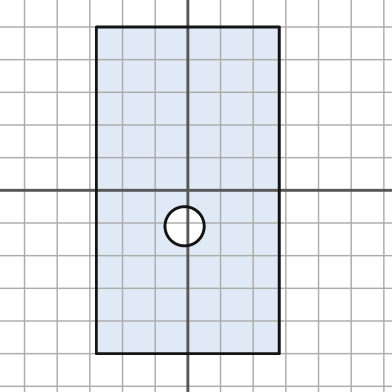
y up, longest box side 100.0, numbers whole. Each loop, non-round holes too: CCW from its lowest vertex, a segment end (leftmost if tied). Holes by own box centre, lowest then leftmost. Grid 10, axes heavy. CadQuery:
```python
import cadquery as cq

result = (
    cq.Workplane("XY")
    .moveTo(-28.0, -50.0)
    .lineTo(28.0, -50.0)
    .lineTo(28.0, 50.0)
    .lineTo(-28.0, 50.0)
    .close()
    .moveTo(-1.0, -11.0)
    .circle(6.0)
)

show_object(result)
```